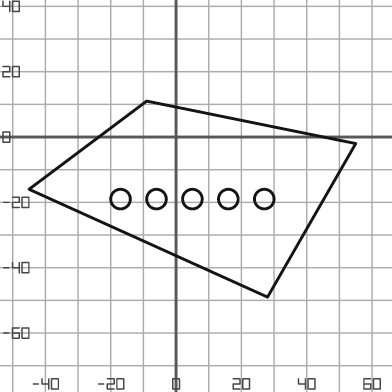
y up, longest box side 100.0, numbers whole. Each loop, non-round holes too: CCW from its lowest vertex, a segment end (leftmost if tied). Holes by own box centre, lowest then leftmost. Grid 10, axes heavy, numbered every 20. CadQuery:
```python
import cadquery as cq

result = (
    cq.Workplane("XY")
    .moveTo(28.0, -49.0)
    .lineTo(55.0, -2.0)
    .lineTo(-9.0, 11.0)
    .lineTo(-45.0, -16.0)
    .close()
    .moveTo(-17.0, -19.0)
    .circle(3.0)
    .moveTo(-6.0, -19.0)
    .circle(3.0)
    .moveTo(5.0, -19.0)
    .circle(3.0)
    .moveTo(16.0, -19.0)
    .circle(3.0)
    .moveTo(27.0, -19.0)
    .circle(3.0)
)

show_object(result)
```